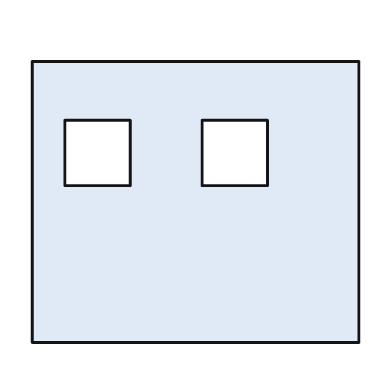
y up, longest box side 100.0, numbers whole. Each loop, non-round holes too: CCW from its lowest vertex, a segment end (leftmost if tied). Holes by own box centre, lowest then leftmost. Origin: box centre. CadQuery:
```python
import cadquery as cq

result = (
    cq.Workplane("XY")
    .moveTo(-50.0, -43.0)
    .lineTo(50.0, -43.0)
    .lineTo(50.0, 43.0)
    .lineTo(-50.0, 43.0)
    .close()
    .moveTo(-40.0, 5.0)
    .lineTo(-20.0, 5.0)
    .lineTo(-20.0, 25.0)
    .lineTo(-40.0, 25.0)
    .close()
    .moveTo(2.0, 5.0)
    .lineTo(22.0, 5.0)
    .lineTo(22.0, 25.0)
    .lineTo(2.0, 25.0)
    .close()
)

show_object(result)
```